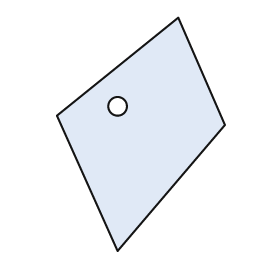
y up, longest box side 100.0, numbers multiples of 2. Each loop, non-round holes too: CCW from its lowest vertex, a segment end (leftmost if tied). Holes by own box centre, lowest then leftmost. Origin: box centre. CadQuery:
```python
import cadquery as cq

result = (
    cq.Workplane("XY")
    .moveTo(-10.0, -50.0)
    .lineTo(36.0, 4.0)
    .lineTo(16.0, 50.0)
    .lineTo(-36.0, 8.0)
    .close()
    .moveTo(-10.0, 12.0)
    .circle(4.0)
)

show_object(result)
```